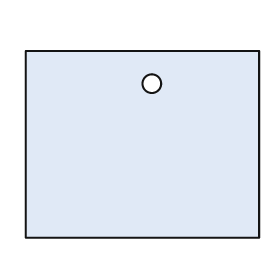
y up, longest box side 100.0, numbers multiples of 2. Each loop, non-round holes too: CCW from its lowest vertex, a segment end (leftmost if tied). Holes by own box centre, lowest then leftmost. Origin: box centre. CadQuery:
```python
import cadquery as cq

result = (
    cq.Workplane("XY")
    .moveTo(-50.0, -40.0)
    .lineTo(50.0, -40.0)
    .lineTo(50.0, 40.0)
    .lineTo(-50.0, 40.0)
    .close()
    .moveTo(4.0, 26.0)
    .circle(4.0)
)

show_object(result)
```